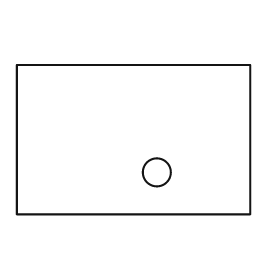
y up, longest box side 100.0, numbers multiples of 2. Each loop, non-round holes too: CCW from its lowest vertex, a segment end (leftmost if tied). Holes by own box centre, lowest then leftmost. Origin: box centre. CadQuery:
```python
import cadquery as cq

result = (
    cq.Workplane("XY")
    .moveTo(-50.0, -32.0)
    .lineTo(50.0, -32.0)
    .lineTo(50.0, 32.0)
    .lineTo(-50.0, 32.0)
    .close()
    .moveTo(10.0, -14.0)
    .circle(6.0)
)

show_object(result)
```